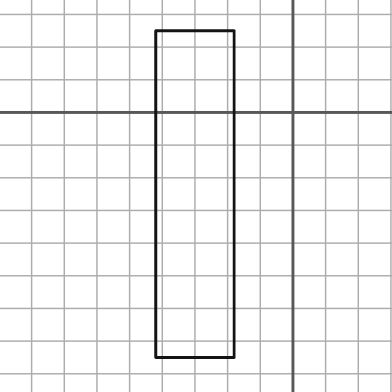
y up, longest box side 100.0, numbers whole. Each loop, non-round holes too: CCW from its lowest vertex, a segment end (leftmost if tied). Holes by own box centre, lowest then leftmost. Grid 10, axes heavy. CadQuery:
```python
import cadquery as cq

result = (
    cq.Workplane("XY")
    .moveTo(-42.0, -75.0)
    .lineTo(-18.0, -75.0)
    .lineTo(-18.0, 25.0)
    .lineTo(-42.0, 25.0)
    .close()
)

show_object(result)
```